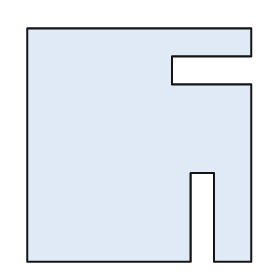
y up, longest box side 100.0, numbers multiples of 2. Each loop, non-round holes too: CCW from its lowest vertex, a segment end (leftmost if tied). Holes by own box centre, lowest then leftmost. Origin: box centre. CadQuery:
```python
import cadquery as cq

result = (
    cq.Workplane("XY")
    .moveTo(-48.0, -50.0)
    .lineTo(22.0, -50.0)
    .lineTo(22.0, -12.0)
    .lineTo(32.0, -12.0)
    .lineTo(32.0, -50.0)
    .lineTo(48.0, -50.0)
    .lineTo(48.0, 26.0)
    .lineTo(14.0, 26.0)
    .lineTo(14.0, 38.0)
    .lineTo(48.0, 38.0)
    .lineTo(48.0, 50.0)
    .lineTo(-48.0, 50.0)
    .close()
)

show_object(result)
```